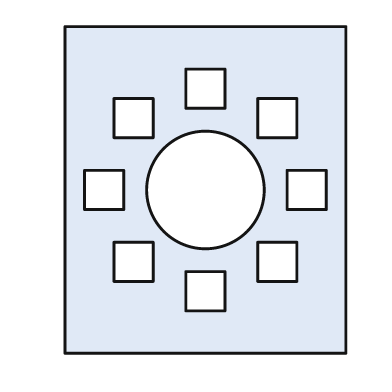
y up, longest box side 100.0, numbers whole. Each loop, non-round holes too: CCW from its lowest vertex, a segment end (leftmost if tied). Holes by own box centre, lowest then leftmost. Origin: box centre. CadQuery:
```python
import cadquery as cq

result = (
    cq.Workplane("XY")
    .moveTo(-43.0, -50.0)
    .lineTo(43.0, -50.0)
    .lineTo(43.0, 50.0)
    .lineTo(-43.0, 50.0)
    .close()
    .moveTo(-6.0, -37.0)
    .lineTo(6.0, -37.0)
    .lineTo(6.0, -25.0)
    .lineTo(-6.0, -25.0)
    .close()
    .moveTo(-28.0, -28.0)
    .lineTo(-16.0, -28.0)
    .lineTo(-16.0, -16.0)
    .lineTo(-28.0, -16.0)
    .close()
    .moveTo(16.0, -28.0)
    .lineTo(28.0, -28.0)
    .lineTo(28.0, -16.0)
    .lineTo(16.0, -16.0)
    .close()
    .moveTo(-37.0, -6.0)
    .lineTo(-25.0, -6.0)
    .lineTo(-25.0, 6.0)
    .lineTo(-37.0, 6.0)
    .close()
    .moveTo(0.0, 0.0)
    .circle(18.0)
    .moveTo(25.0, -6.0)
    .lineTo(37.0, -6.0)
    .lineTo(37.0, 6.0)
    .lineTo(25.0, 6.0)
    .close()
    .moveTo(-28.0, 16.0)
    .lineTo(-16.0, 16.0)
    .lineTo(-16.0, 28.0)
    .lineTo(-28.0, 28.0)
    .close()
    .moveTo(16.0, 16.0)
    .lineTo(28.0, 16.0)
    .lineTo(28.0, 28.0)
    .lineTo(16.0, 28.0)
    .close()
    .moveTo(-6.0, 25.0)
    .lineTo(6.0, 25.0)
    .lineTo(6.0, 37.0)
    .lineTo(-6.0, 37.0)
    .close()
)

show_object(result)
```